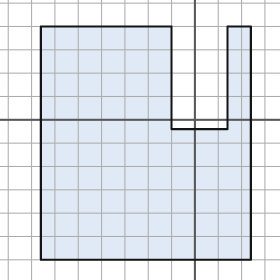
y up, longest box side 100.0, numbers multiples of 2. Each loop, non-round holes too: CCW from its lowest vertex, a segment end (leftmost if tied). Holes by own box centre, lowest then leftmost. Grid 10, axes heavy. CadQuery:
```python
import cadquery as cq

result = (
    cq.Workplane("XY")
    .moveTo(-66.0, -60.0)
    .lineTo(24.0, -60.0)
    .lineTo(24.0, 40.0)
    .lineTo(14.0, 40.0)
    .lineTo(14.0, -4.0)
    .lineTo(-10.0, -4.0)
    .lineTo(-10.0, 40.0)
    .lineTo(-66.0, 40.0)
    .close()
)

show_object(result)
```